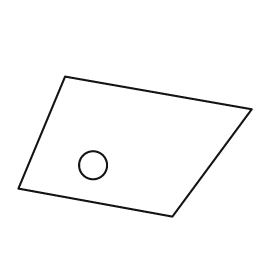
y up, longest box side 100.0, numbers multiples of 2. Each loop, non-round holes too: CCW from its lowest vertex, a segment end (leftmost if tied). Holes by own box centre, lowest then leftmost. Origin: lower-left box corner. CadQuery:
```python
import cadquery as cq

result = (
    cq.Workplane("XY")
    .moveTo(66.0, 0.0)
    .lineTo(100.0, 46.0)
    .lineTo(20.0, 60.0)
    .lineTo(0.0, 12.0)
    .close()
    .moveTo(32.0, 22.0)
    .circle(6.0)
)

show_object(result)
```